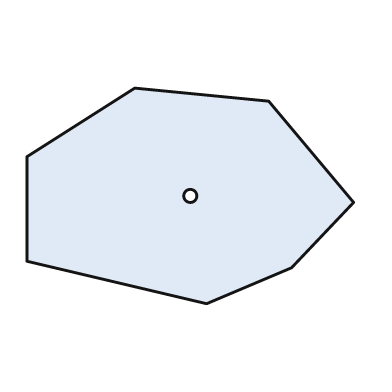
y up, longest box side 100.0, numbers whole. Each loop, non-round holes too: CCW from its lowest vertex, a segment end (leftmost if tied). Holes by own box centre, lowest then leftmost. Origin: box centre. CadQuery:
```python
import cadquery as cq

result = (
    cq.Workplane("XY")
    .moveTo(5.0, -33.0)
    .lineTo(31.0, -22.0)
    .lineTo(50.0, -2.0)
    .lineTo(24.0, 29.0)
    .lineTo(-17.0, 33.0)
    .lineTo(-50.0, 12.0)
    .lineTo(-50.0, -20.0)
    .close()
    .moveTo(0.0, 0.0)
    .circle(2.0)
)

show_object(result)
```